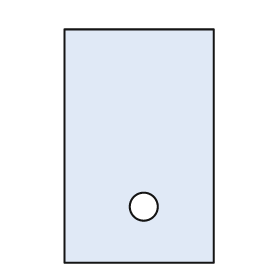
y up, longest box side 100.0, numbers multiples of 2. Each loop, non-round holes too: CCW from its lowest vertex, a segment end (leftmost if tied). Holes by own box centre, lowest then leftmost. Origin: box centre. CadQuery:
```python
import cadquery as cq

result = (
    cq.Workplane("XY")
    .moveTo(-32.0, -50.0)
    .lineTo(32.0, -50.0)
    .lineTo(32.0, 50.0)
    .lineTo(-32.0, 50.0)
    .close()
    .moveTo(2.0, -26.0)
    .circle(6.0)
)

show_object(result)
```